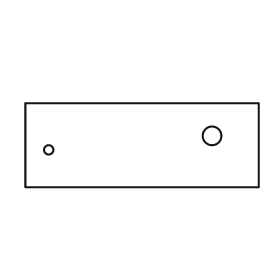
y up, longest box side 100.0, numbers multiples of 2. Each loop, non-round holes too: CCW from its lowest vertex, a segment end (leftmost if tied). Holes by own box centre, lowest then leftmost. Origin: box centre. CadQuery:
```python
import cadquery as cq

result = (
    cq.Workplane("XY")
    .moveTo(-50.0, -18.0)
    .lineTo(50.0, -18.0)
    .lineTo(50.0, 18.0)
    .lineTo(-50.0, 18.0)
    .close()
    .moveTo(-40.0, -2.0)
    .circle(2.0)
    .moveTo(30.0, 4.0)
    .circle(4.0)
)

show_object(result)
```